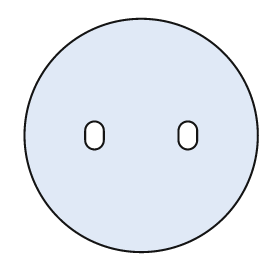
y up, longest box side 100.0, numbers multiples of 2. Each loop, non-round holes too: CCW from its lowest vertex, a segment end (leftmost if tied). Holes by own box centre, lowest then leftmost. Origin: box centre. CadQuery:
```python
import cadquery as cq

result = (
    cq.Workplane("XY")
    .moveTo(0.0, 0.0)
    .circle(50.0)
    .moveTo(-24.0, -2.0)
    .threePointArc((-20.0, -6.0), (-16.0, -2.0))
    .lineTo(-16.0, 2.0)
    .threePointArc((-20.0, 6.0), (-24.0, 2.0))
    .close()
    .moveTo(16.0, -2.0)
    .threePointArc((20.0, -6.0), (24.0, -2.0))
    .lineTo(24.0, 2.0)
    .threePointArc((20.0, 6.0), (16.0, 2.0))
    .close()
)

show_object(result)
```